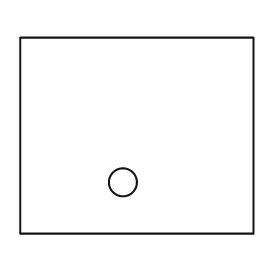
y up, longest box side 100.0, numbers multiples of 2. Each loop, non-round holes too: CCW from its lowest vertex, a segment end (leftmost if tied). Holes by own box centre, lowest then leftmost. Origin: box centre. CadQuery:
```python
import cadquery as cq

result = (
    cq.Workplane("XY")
    .moveTo(-50.0, -42.0)
    .lineTo(50.0, -42.0)
    .lineTo(50.0, 42.0)
    .lineTo(-50.0, 42.0)
    .close()
    .moveTo(-6.0, -20.0)
    .circle(6.0)
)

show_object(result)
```